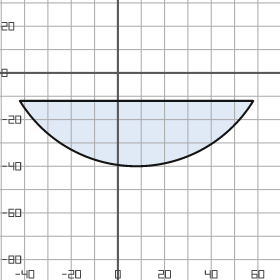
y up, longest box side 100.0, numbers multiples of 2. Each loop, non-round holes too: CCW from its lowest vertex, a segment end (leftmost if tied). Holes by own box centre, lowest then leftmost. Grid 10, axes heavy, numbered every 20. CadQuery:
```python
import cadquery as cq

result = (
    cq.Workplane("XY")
    .moveTo(-42.0, -12.0)
    .threePointArc((8.0, -40.0), (58.0, -12.0))
    .close()
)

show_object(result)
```